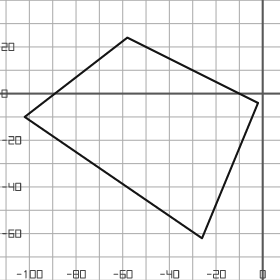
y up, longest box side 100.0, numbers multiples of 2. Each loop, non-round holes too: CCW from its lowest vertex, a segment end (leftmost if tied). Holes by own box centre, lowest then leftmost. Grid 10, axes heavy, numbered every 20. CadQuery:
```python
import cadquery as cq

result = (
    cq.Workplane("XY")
    .moveTo(-26.0, -62.0)
    .lineTo(-2.0, -4.0)
    .lineTo(-58.0, 24.0)
    .lineTo(-102.0, -10.0)
    .close()
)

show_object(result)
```